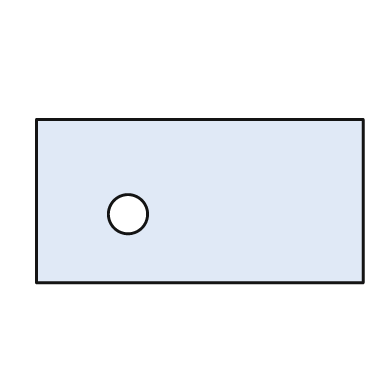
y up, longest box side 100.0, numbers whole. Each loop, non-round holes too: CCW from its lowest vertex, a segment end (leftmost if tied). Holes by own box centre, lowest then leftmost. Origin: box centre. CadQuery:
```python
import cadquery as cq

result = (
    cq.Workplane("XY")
    .moveTo(-50.0, -25.0)
    .lineTo(50.0, -25.0)
    .lineTo(50.0, 25.0)
    .lineTo(-50.0, 25.0)
    .close()
    .moveTo(-22.0, -4.0)
    .circle(6.0)
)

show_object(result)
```